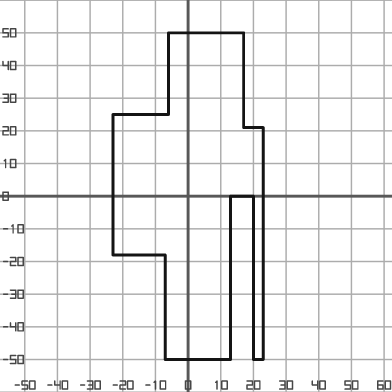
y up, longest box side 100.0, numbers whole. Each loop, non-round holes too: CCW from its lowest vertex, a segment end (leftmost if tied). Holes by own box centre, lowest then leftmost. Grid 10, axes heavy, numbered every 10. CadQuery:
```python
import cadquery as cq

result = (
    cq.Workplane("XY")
    .moveTo(-7.0, -50.0)
    .lineTo(13.0, -50.0)
    .lineTo(13.0, 0.0)
    .lineTo(20.0, 0.0)
    .lineTo(20.0, -50.0)
    .lineTo(23.0, -50.0)
    .lineTo(23.0, 21.0)
    .lineTo(17.0, 21.0)
    .lineTo(17.0, 50.0)
    .lineTo(-6.0, 50.0)
    .lineTo(-6.0, 25.0)
    .lineTo(-23.0, 25.0)
    .lineTo(-23.0, -18.0)
    .lineTo(-7.0, -18.0)
    .close()
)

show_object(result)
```